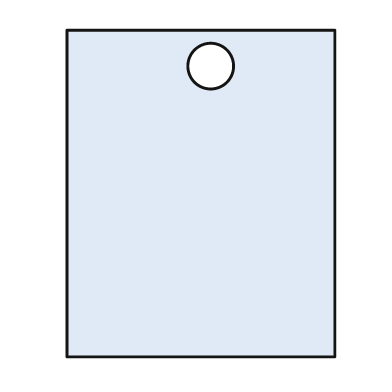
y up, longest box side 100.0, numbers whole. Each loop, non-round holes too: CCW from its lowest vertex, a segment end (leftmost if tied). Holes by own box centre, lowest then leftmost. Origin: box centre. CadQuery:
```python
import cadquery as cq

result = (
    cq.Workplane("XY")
    .moveTo(-41.0, -50.0)
    .lineTo(41.0, -50.0)
    .lineTo(41.0, 50.0)
    .lineTo(-41.0, 50.0)
    .close()
    .moveTo(3.0, 39.0)
    .circle(7.0)
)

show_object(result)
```